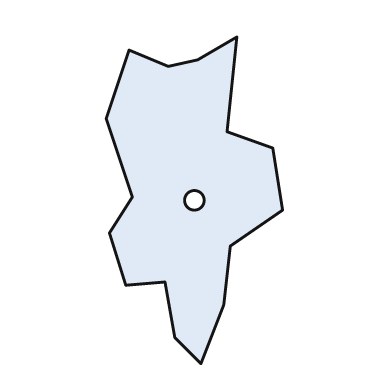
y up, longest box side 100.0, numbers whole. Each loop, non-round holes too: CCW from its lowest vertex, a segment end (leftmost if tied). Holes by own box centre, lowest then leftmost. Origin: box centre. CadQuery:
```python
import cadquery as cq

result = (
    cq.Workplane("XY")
    .moveTo(2.0, -50.0)
    .lineTo(9.0, -32.0)
    .lineTo(11.0, -14.0)
    .lineTo(27.0, -3.0)
    .lineTo(24.0, 16.0)
    .lineTo(10.0, 21.0)
    .lineTo(13.0, 50.0)
    .lineTo(1.0, 43.0)
    .lineTo(-8.0, 41.0)
    .lineTo(-20.0, 46.0)
    .lineTo(-27.0, 25.0)
    .lineTo(-19.0, 1.0)
    .lineTo(-26.0, -10.0)
    .lineTo(-21.0, -26.0)
    .lineTo(-9.0, -25.0)
    .lineTo(-6.0, -42.0)
    .close()
    .moveTo(0.0, 0.0)
    .circle(3.0)
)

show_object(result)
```